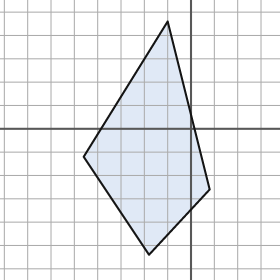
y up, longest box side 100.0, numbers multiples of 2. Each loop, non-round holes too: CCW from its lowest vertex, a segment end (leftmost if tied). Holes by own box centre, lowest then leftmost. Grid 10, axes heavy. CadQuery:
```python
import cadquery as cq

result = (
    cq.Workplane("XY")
    .moveTo(-18.0, -54.0)
    .lineTo(8.0, -26.0)
    .lineTo(-10.0, 46.0)
    .lineTo(-46.0, -12.0)
    .close()
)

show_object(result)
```